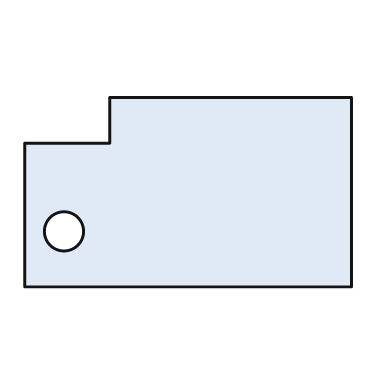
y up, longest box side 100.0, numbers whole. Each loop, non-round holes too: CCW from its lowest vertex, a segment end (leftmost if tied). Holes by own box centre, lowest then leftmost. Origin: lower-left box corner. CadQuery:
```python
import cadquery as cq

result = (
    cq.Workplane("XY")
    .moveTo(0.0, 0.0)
    .lineTo(100.0, 0.0)
    .lineTo(100.0, 58.0)
    .lineTo(26.0, 58.0)
    .lineTo(26.0, 44.0)
    .lineTo(0.0, 44.0)
    .close()
    .moveTo(12.0, 17.0)
    .circle(6.0)
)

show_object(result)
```